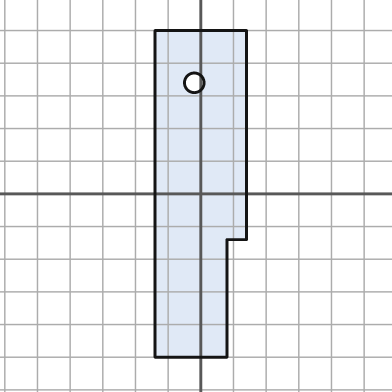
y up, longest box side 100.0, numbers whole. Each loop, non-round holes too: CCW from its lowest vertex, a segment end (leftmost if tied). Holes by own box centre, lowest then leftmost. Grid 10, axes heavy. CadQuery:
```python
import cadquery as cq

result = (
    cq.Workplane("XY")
    .moveTo(-14.0, -50.0)
    .lineTo(8.0, -50.0)
    .lineTo(8.0, -14.0)
    .lineTo(14.0, -14.0)
    .lineTo(14.0, 50.0)
    .lineTo(-14.0, 50.0)
    .close()
    .moveTo(-2.0, 34.0)
    .circle(3.0)
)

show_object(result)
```